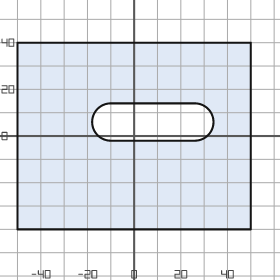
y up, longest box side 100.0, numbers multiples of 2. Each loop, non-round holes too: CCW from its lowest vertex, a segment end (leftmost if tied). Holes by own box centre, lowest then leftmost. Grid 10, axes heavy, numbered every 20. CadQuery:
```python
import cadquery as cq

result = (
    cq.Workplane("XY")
    .moveTo(-50.0, -40.0)
    .lineTo(50.0, -40.0)
    .lineTo(50.0, 40.0)
    .lineTo(-50.0, 40.0)
    .close()
    .moveTo(-10.0, -2.0)
    .lineTo(26.0, -2.0)
    .threePointArc((34.0, 6.0), (26.0, 14.0))
    .lineTo(-10.0, 14.0)
    .threePointArc((-18.0, 6.0), (-10.0, -2.0))
    .close()
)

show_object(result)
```